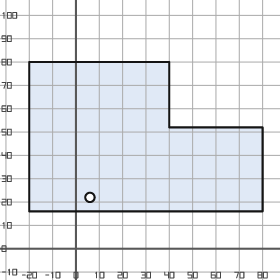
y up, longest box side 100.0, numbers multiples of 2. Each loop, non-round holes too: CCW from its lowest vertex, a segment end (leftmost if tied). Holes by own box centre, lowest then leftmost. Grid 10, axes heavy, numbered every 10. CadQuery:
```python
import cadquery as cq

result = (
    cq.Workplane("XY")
    .moveTo(-20.0, 16.0)
    .lineTo(80.0, 16.0)
    .lineTo(80.0, 52.0)
    .lineTo(40.0, 52.0)
    .lineTo(40.0, 80.0)
    .lineTo(-20.0, 80.0)
    .close()
    .moveTo(6.0, 22.0)
    .circle(2.0)
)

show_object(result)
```